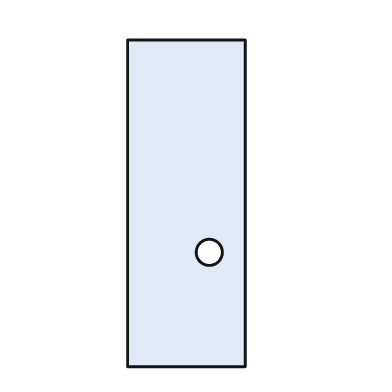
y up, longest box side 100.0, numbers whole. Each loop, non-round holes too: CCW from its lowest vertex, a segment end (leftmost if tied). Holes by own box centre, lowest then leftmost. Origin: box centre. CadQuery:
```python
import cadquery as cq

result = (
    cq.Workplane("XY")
    .moveTo(-18.0, -50.0)
    .lineTo(18.0, -50.0)
    .lineTo(18.0, 50.0)
    .lineTo(-18.0, 50.0)
    .close()
    .moveTo(7.0, -15.0)
    .circle(4.0)
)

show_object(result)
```